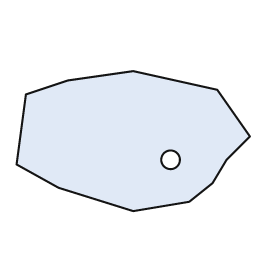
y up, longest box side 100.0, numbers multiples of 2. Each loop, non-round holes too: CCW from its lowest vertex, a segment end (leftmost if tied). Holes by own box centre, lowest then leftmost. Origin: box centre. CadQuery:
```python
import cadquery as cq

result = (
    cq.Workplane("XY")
    .moveTo(0.0, -30.0)
    .lineTo(24.0, -26.0)
    .lineTo(34.0, -18.0)
    .lineTo(40.0, -8.0)
    .lineTo(50.0, 2.0)
    .lineTo(36.0, 22.0)
    .lineTo(0.0, 30.0)
    .lineTo(-28.0, 26.0)
    .lineTo(-46.0, 20.0)
    .lineTo(-50.0, -10.0)
    .lineTo(-32.0, -20.0)
    .close()
    .moveTo(16.0, -8.0)
    .circle(4.0)
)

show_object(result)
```